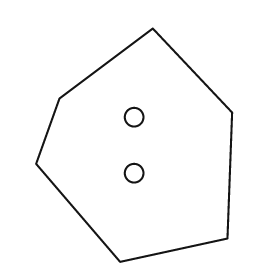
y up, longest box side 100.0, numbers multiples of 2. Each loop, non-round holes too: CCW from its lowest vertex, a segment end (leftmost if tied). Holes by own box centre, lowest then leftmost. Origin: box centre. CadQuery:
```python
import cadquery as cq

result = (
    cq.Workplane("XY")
    .moveTo(-6.0, -50.0)
    .lineTo(40.0, -40.0)
    .lineTo(42.0, 14.0)
    .lineTo(8.0, 50.0)
    .lineTo(-32.0, 20.0)
    .lineTo(-42.0, -8.0)
    .close()
    .moveTo(0.0, -12.0)
    .circle(4.0)
    .moveTo(0.0, 12.0)
    .circle(4.0)
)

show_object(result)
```